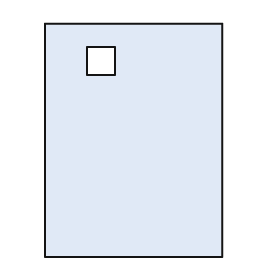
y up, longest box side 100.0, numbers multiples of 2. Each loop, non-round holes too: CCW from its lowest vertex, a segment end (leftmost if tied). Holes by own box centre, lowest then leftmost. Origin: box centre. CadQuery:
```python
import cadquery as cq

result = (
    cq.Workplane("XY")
    .moveTo(-38.0, -50.0)
    .lineTo(38.0, -50.0)
    .lineTo(38.0, 50.0)
    .lineTo(-38.0, 50.0)
    .close()
    .moveTo(-20.0, 28.0)
    .lineTo(-8.0, 28.0)
    .lineTo(-8.0, 40.0)
    .lineTo(-20.0, 40.0)
    .close()
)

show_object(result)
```